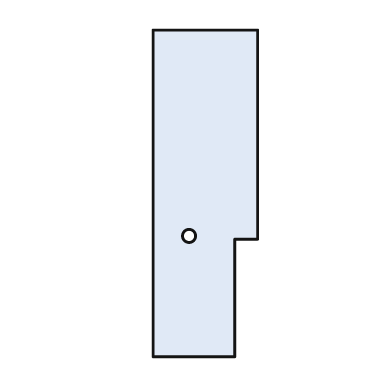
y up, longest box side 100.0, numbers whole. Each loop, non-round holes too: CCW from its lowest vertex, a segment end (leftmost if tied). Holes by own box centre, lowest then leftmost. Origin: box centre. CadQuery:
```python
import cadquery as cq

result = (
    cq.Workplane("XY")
    .moveTo(-16.0, -50.0)
    .lineTo(9.0, -50.0)
    .lineTo(9.0, -14.0)
    .lineTo(16.0, -14.0)
    .lineTo(16.0, 50.0)
    .lineTo(-16.0, 50.0)
    .close()
    .moveTo(-5.0, -13.0)
    .circle(2.0)
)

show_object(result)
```